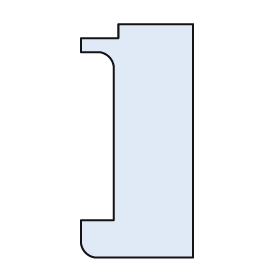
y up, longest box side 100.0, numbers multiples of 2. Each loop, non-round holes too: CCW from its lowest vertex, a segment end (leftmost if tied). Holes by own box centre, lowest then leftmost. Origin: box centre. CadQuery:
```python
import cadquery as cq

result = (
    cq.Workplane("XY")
    .moveTo(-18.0, -50.0)
    .lineTo(24.0, -50.0)
    .lineTo(24.0, 50.0)
    .lineTo(-8.0, 50.0)
    .lineTo(-8.0, 44.0)
    .lineTo(-24.0, 44.0)
    .lineTo(-24.0, 38.0)
    .lineTo(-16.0, 38.0)
    .threePointArc((-12.0, 36.0), (-10.0, 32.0))
    .lineTo(-10.0, -34.0)
    .lineTo(-24.0, -34.0)
    .lineTo(-24.0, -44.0)
    .threePointArc((-22.0, -48.0), (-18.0, -50.0))
    .close()
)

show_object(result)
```